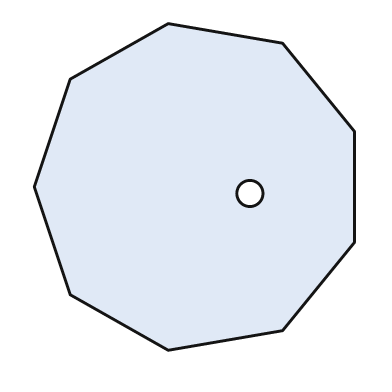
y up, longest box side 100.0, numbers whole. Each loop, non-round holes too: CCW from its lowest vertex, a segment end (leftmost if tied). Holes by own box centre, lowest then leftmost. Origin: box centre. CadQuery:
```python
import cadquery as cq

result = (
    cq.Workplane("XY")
    .moveTo(-8.0, -50.0)
    .lineTo(27.0, -44.0)
    .lineTo(49.0, -17.0)
    .lineTo(49.0, 17.0)
    .lineTo(27.0, 44.0)
    .lineTo(-8.0, 50.0)
    .lineTo(-38.0, 33.0)
    .lineTo(-49.0, 0.0)
    .lineTo(-38.0, -33.0)
    .close()
    .moveTo(17.0, -2.0)
    .circle(4.0)
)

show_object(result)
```